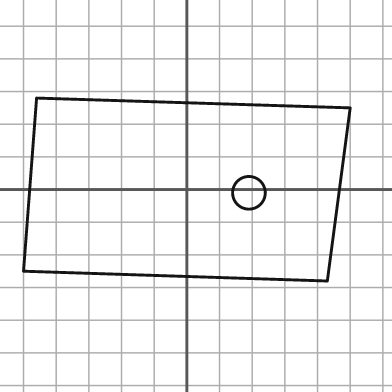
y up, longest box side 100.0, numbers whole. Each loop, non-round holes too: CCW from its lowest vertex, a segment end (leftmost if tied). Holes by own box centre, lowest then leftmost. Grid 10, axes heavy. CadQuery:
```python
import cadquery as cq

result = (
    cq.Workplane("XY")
    .moveTo(43.0, -28.0)
    .lineTo(50.0, 25.0)
    .lineTo(-46.0, 28.0)
    .lineTo(-50.0, -25.0)
    .close()
    .moveTo(19.0, -1.0)
    .circle(5.0)
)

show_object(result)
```